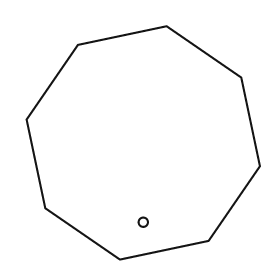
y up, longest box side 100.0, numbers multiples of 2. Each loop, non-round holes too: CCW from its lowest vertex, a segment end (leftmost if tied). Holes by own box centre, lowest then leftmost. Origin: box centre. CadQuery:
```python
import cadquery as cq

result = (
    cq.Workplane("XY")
    .moveTo(-10.0, -50.0)
    .lineTo(28.0, -42.0)
    .lineTo(50.0, -10.0)
    .lineTo(42.0, 28.0)
    .lineTo(10.0, 50.0)
    .lineTo(-28.0, 42.0)
    .lineTo(-50.0, 10.0)
    .lineTo(-42.0, -28.0)
    .close()
    .moveTo(0.0, -34.0)
    .circle(2.0)
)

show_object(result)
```